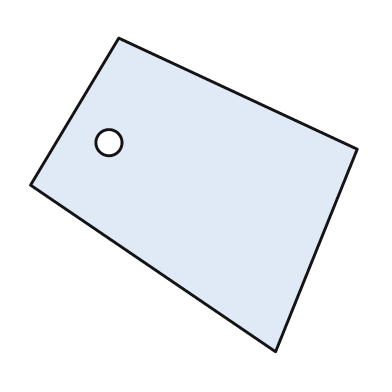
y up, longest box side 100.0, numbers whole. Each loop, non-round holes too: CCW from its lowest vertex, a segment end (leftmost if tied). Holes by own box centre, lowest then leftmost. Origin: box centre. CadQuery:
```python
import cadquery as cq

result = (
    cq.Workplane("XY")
    .moveTo(25.0, -48.0)
    .lineTo(50.0, 14.0)
    .lineTo(-23.0, 48.0)
    .lineTo(-50.0, 3.0)
    .close()
    .moveTo(-26.0, 16.0)
    .circle(4.0)
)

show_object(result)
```